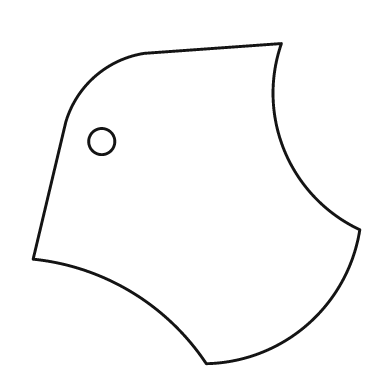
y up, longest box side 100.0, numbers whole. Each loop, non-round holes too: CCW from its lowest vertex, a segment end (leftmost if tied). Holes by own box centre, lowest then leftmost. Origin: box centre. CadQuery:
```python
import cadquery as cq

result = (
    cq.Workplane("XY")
    .moveTo(3.0, -49.0)
    .threePointArc((34.0, -37.0), (50.0, -8.0))
    .threePointArc((27.0, 16.0), (26.0, 49.0))
    .lineTo(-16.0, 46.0)
    .threePointArc((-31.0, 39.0), (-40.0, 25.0))
    .lineTo(-50.0, -17.0)
    .threePointArc((-20.0, -27.0), (3.0, -49.0))
    .close()
    .moveTo(-29.0, 19.0)
    .circle(4.0)
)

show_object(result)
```